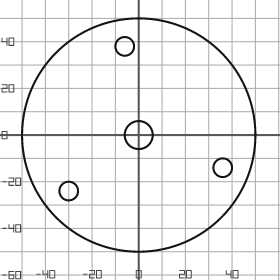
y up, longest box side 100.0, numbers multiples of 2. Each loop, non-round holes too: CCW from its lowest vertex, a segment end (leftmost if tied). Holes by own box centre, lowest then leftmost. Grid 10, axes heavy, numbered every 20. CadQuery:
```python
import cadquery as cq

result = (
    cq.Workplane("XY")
    .moveTo(0.0, 0.0)
    .circle(50.0)
    .moveTo(-30.0, -24.0)
    .circle(4.0)
    .moveTo(36.0, -14.0)
    .circle(4.0)
    .moveTo(0.0, 0.0)
    .circle(6.0)
    .moveTo(-6.0, 38.0)
    .circle(4.0)
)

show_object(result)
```